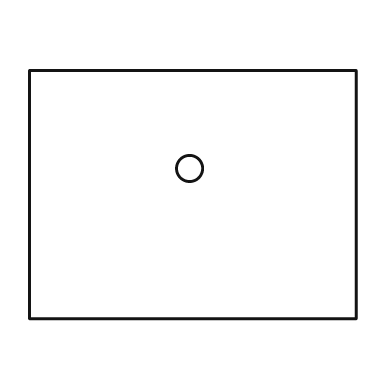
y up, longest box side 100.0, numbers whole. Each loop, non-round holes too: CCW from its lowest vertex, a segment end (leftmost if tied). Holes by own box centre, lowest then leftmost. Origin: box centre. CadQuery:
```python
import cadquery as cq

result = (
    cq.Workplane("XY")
    .moveTo(-50.0, -38.0)
    .lineTo(50.0, -38.0)
    .lineTo(50.0, 38.0)
    .lineTo(-50.0, 38.0)
    .close()
    .moveTo(-1.0, 8.0)
    .circle(4.0)
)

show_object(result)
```